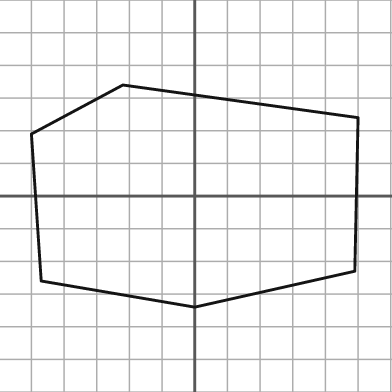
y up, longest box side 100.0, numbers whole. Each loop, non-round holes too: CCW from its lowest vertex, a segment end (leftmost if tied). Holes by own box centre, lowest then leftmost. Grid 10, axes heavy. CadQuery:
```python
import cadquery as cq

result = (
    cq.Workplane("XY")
    .moveTo(0.0, -34.0)
    .lineTo(49.0, -23.0)
    .lineTo(50.0, 24.0)
    .lineTo(-22.0, 34.0)
    .lineTo(-50.0, 19.0)
    .lineTo(-47.0, -26.0)
    .close()
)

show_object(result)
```